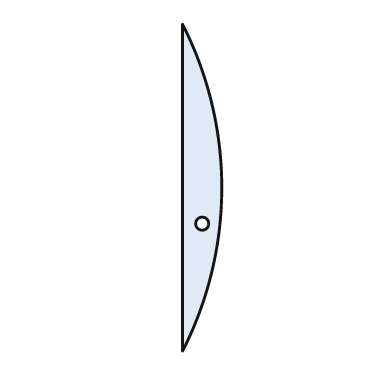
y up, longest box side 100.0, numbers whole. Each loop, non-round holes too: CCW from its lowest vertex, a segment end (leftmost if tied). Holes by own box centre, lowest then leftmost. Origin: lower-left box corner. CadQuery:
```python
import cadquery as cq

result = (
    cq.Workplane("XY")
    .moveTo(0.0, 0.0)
    .threePointArc((12.0, 50.0), (0.0, 100.0))
    .close()
    .moveTo(6.0, 39.0)
    .circle(2.0)
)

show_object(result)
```